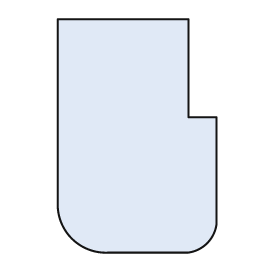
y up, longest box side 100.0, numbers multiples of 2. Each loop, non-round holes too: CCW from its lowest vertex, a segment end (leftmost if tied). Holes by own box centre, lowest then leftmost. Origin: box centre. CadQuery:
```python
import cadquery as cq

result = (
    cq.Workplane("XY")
    .moveTo(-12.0, -50.0)
    .lineTo(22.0, -50.0)
    .threePointArc((30.0, -46.0), (34.0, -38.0))
    .lineTo(34.0, 8.0)
    .lineTo(22.0, 8.0)
    .lineTo(22.0, 50.0)
    .lineTo(-34.0, 50.0)
    .lineTo(-34.0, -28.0)
    .threePointArc((-28.0, -44.0), (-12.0, -50.0))
    .close()
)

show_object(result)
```